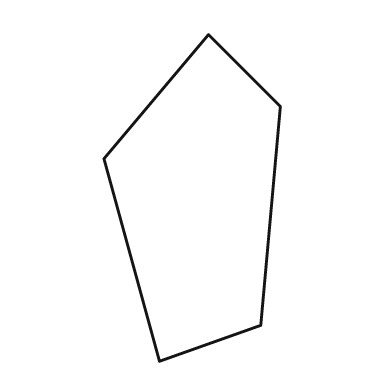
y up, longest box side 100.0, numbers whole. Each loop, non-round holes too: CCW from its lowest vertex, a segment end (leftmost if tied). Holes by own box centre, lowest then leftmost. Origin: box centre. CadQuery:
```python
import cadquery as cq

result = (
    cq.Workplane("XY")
    .moveTo(-10.0, -50.0)
    .lineTo(21.0, -39.0)
    .lineTo(27.0, 28.0)
    .lineTo(5.0, 50.0)
    .lineTo(-27.0, 12.0)
    .close()
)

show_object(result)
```